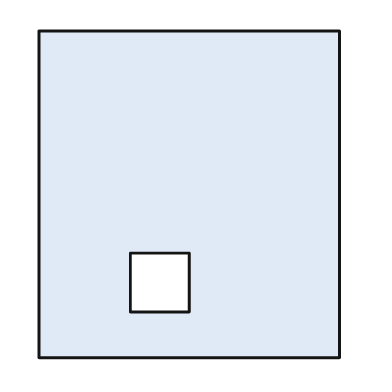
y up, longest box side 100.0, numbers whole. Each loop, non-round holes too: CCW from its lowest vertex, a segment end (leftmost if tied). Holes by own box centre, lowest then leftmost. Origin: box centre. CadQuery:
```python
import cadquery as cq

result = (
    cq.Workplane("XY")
    .moveTo(-46.0, -50.0)
    .lineTo(46.0, -50.0)
    .lineTo(46.0, 50.0)
    .lineTo(-46.0, 50.0)
    .close()
    .moveTo(-18.0, -36.0)
    .lineTo(0.0, -36.0)
    .lineTo(0.0, -18.0)
    .lineTo(-18.0, -18.0)
    .close()
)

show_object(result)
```